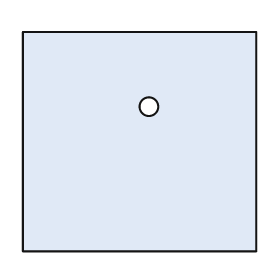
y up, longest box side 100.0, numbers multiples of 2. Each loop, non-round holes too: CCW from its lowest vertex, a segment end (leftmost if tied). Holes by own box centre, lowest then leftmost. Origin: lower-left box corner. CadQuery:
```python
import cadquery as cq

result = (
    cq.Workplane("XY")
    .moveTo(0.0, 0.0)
    .lineTo(100.0, 0.0)
    .lineTo(100.0, 94.0)
    .lineTo(0.0, 94.0)
    .close()
    .moveTo(54.0, 62.0)
    .circle(4.0)
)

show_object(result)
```